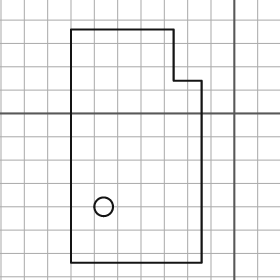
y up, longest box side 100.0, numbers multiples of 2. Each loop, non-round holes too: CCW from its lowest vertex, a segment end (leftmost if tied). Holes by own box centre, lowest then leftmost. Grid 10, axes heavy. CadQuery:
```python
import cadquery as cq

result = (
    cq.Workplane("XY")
    .moveTo(-70.0, -64.0)
    .lineTo(-14.0, -64.0)
    .lineTo(-14.0, 14.0)
    .lineTo(-26.0, 14.0)
    .lineTo(-26.0, 36.0)
    .lineTo(-70.0, 36.0)
    .close()
    .moveTo(-56.0, -40.0)
    .circle(4.0)
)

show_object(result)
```